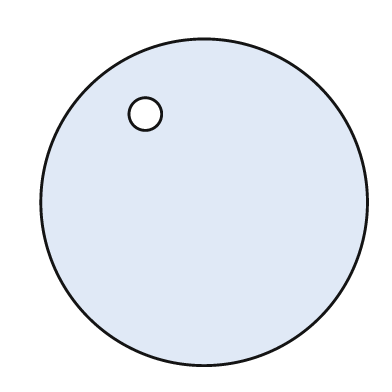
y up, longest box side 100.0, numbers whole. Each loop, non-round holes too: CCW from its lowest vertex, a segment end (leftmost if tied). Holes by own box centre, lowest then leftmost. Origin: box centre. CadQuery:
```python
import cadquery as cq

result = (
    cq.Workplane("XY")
    .moveTo(0.0, 0.0)
    .circle(50.0)
    .moveTo(-18.0, 27.0)
    .circle(5.0)
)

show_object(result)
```